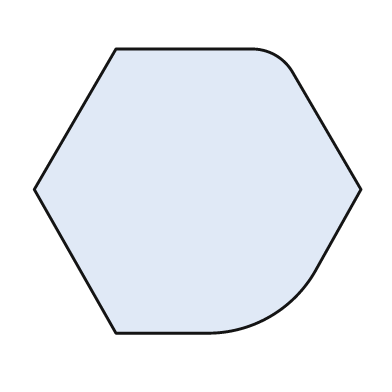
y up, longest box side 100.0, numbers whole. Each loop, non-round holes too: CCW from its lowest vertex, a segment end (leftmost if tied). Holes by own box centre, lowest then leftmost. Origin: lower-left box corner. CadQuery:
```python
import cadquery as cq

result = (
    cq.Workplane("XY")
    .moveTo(25.0, 0.0)
    .lineTo(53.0, 0.0)
    .threePointArc((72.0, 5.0), (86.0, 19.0))
    .lineTo(100.0, 44.0)
    .lineTo(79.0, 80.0)
    .threePointArc((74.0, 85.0), (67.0, 87.0))
    .lineTo(25.0, 87.0)
    .lineTo(0.0, 44.0)
    .close()
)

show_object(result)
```